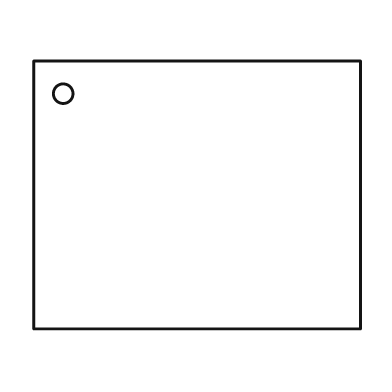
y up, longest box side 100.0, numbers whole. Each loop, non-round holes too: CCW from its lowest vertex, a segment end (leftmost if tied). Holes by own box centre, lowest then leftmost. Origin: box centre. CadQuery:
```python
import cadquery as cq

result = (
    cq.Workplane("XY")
    .moveTo(-50.0, -41.0)
    .lineTo(50.0, -41.0)
    .lineTo(50.0, 41.0)
    .lineTo(-50.0, 41.0)
    .close()
    .moveTo(-41.0, 31.0)
    .circle(3.0)
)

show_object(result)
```